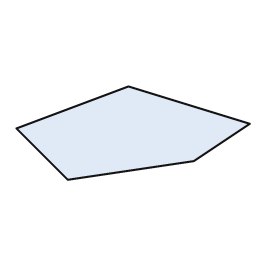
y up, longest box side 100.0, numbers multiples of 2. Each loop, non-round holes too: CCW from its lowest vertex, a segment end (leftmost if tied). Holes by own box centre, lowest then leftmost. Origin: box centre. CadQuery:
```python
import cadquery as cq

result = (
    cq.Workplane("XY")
    .moveTo(-28.0, -20.0)
    .lineTo(26.0, -12.0)
    .lineTo(50.0, 4.0)
    .lineTo(-2.0, 20.0)
    .lineTo(-50.0, 2.0)
    .close()
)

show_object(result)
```